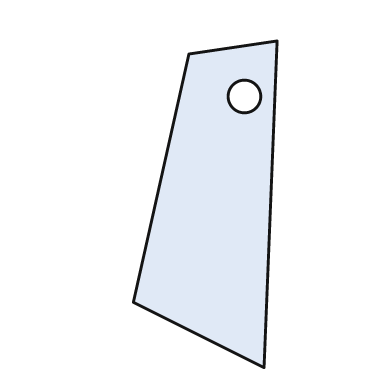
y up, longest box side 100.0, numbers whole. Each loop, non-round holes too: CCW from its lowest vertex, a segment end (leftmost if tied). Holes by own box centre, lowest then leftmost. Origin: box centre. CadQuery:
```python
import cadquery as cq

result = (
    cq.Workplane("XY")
    .moveTo(18.0, -50.0)
    .lineTo(22.0, 50.0)
    .lineTo(-5.0, 46.0)
    .lineTo(-22.0, -30.0)
    .close()
    .moveTo(12.0, 33.0)
    .circle(5.0)
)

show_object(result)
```